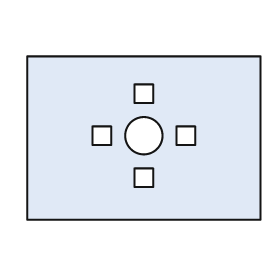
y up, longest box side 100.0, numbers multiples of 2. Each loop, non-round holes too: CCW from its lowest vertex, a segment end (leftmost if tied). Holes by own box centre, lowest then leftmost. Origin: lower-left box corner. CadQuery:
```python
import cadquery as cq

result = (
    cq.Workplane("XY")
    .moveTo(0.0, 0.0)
    .lineTo(100.0, 0.0)
    .lineTo(100.0, 70.0)
    .lineTo(0.0, 70.0)
    .close()
    .moveTo(46.0, 14.0)
    .lineTo(54.0, 14.0)
    .lineTo(54.0, 22.0)
    .lineTo(46.0, 22.0)
    .close()
    .moveTo(28.0, 32.0)
    .lineTo(36.0, 32.0)
    .lineTo(36.0, 40.0)
    .lineTo(28.0, 40.0)
    .close()
    .moveTo(50.0, 36.0)
    .circle(8.0)
    .moveTo(64.0, 32.0)
    .lineTo(72.0, 32.0)
    .lineTo(72.0, 40.0)
    .lineTo(64.0, 40.0)
    .close()
    .moveTo(46.0, 50.0)
    .lineTo(54.0, 50.0)
    .lineTo(54.0, 58.0)
    .lineTo(46.0, 58.0)
    .close()
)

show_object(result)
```